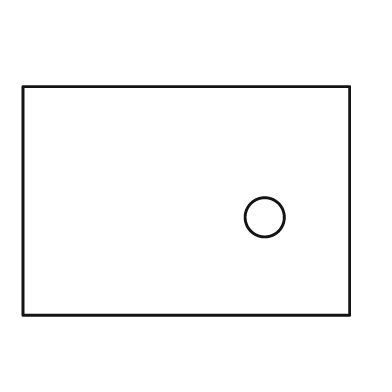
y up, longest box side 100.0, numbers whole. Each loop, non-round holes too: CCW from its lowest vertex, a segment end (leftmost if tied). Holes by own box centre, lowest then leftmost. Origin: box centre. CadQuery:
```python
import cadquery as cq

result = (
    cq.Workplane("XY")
    .moveTo(-50.0, -35.0)
    .lineTo(50.0, -35.0)
    .lineTo(50.0, 35.0)
    .lineTo(-50.0, 35.0)
    .close()
    .moveTo(24.0, -5.0)
    .circle(6.0)
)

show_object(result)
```